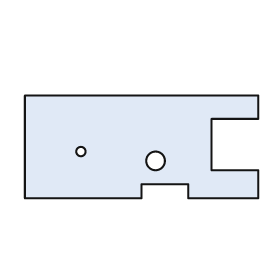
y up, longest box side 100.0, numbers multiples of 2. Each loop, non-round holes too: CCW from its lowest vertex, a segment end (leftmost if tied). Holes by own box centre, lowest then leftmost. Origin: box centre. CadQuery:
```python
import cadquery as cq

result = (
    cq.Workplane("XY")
    .moveTo(-50.0, -22.0)
    .lineTo(0.0, -22.0)
    .lineTo(0.0, -16.0)
    .lineTo(20.0, -16.0)
    .lineTo(20.0, -22.0)
    .lineTo(50.0, -22.0)
    .lineTo(50.0, -10.0)
    .lineTo(30.0, -10.0)
    .lineTo(30.0, 12.0)
    .lineTo(50.0, 12.0)
    .lineTo(50.0, 22.0)
    .lineTo(-50.0, 22.0)
    .close()
    .moveTo(6.0, -6.0)
    .circle(4.0)
    .moveTo(-26.0, -2.0)
    .circle(2.0)
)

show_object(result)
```